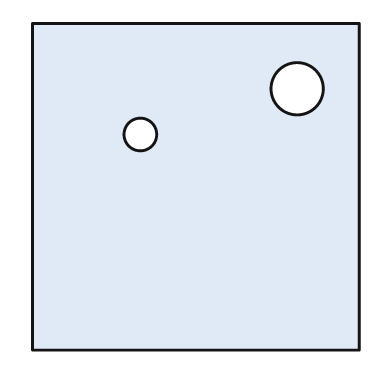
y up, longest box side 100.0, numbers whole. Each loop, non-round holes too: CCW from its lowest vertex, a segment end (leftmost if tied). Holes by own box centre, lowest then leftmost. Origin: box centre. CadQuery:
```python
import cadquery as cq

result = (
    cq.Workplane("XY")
    .moveTo(-50.0, -50.0)
    .lineTo(50.0, -50.0)
    .lineTo(50.0, 50.0)
    .lineTo(-50.0, 50.0)
    .close()
    .moveTo(-17.0, 16.0)
    .circle(5.0)
    .moveTo(31.0, 30.0)
    .circle(8.0)
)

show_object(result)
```